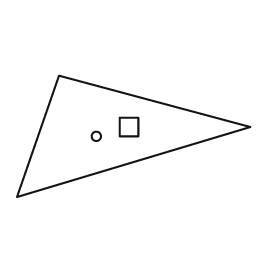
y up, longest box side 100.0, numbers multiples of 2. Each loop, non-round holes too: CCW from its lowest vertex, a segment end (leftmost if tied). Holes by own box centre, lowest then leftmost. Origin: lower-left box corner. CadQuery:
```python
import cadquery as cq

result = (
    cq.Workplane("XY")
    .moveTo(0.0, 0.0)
    .lineTo(100.0, 30.0)
    .lineTo(18.0, 52.0)
    .close()
    .moveTo(34.0, 26.0)
    .circle(2.0)
    .moveTo(44.0, 26.0)
    .lineTo(52.0, 26.0)
    .lineTo(52.0, 34.0)
    .lineTo(44.0, 34.0)
    .close()
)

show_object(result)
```